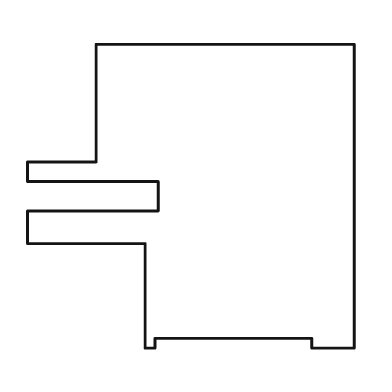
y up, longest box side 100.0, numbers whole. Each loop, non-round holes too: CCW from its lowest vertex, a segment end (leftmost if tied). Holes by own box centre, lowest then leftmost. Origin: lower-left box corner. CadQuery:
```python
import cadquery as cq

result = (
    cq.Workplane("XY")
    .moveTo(36.0, 0.0)
    .lineTo(39.0, 0.0)
    .lineTo(39.0, 3.0)
    .lineTo(87.0, 3.0)
    .lineTo(87.0, 0.0)
    .lineTo(100.0, 0.0)
    .lineTo(100.0, 93.0)
    .lineTo(21.0, 93.0)
    .lineTo(21.0, 57.0)
    .lineTo(0.0, 57.0)
    .lineTo(0.0, 51.0)
    .lineTo(40.0, 51.0)
    .lineTo(40.0, 42.0)
    .lineTo(0.0, 42.0)
    .lineTo(0.0, 32.0)
    .lineTo(36.0, 32.0)
    .close()
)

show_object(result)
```